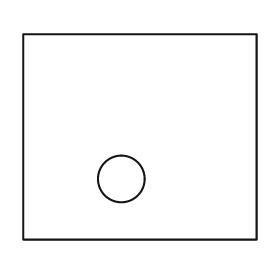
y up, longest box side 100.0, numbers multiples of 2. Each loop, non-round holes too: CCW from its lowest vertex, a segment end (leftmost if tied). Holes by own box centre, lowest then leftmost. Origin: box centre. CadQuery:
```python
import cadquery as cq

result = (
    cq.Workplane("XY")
    .moveTo(-50.0, -44.0)
    .lineTo(50.0, -44.0)
    .lineTo(50.0, 44.0)
    .lineTo(-50.0, 44.0)
    .close()
    .moveTo(-8.0, -18.0)
    .circle(10.0)
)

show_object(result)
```